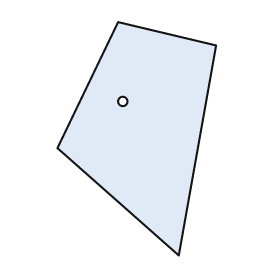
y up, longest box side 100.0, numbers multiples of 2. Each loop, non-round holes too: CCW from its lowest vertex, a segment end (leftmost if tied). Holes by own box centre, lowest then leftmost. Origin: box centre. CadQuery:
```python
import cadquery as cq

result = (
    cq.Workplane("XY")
    .moveTo(18.0, -50.0)
    .lineTo(34.0, 40.0)
    .lineTo(-8.0, 50.0)
    .lineTo(-34.0, -4.0)
    .close()
    .moveTo(-6.0, 16.0)
    .circle(2.0)
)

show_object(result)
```